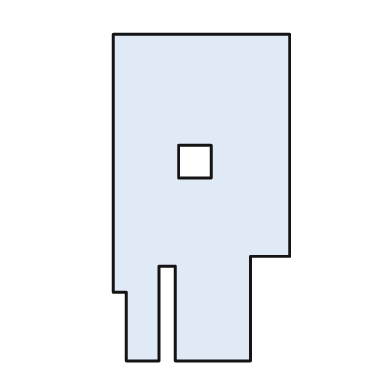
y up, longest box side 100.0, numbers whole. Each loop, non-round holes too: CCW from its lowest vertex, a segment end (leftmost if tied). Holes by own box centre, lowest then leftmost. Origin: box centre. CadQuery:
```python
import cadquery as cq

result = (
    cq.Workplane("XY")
    .moveTo(-23.0, -50.0)
    .lineTo(-13.0, -50.0)
    .lineTo(-13.0, -21.0)
    .lineTo(-8.0, -21.0)
    .lineTo(-8.0, -50.0)
    .lineTo(15.0, -50.0)
    .lineTo(15.0, -18.0)
    .lineTo(27.0, -18.0)
    .lineTo(27.0, 50.0)
    .lineTo(-27.0, 50.0)
    .lineTo(-27.0, -29.0)
    .lineTo(-23.0, -29.0)
    .close()
    .moveTo(-7.0, 6.0)
    .lineTo(3.0, 6.0)
    .lineTo(3.0, 16.0)
    .lineTo(-7.0, 16.0)
    .close()
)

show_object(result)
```